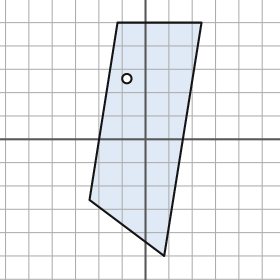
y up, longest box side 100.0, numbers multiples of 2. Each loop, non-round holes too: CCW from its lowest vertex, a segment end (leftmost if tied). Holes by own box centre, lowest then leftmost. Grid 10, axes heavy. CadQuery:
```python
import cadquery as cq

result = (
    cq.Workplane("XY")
    .moveTo(8.0, -50.0)
    .lineTo(24.0, 50.0)
    .lineTo(-12.0, 50.0)
    .lineTo(-24.0, -26.0)
    .close()
    .moveTo(-8.0, 26.0)
    .circle(2.0)
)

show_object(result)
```